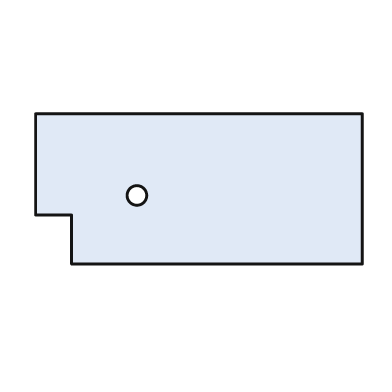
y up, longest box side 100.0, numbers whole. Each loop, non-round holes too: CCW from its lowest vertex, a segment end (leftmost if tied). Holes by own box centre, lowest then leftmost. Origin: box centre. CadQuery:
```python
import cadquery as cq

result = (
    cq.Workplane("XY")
    .moveTo(-39.0, -23.0)
    .lineTo(50.0, -23.0)
    .lineTo(50.0, 23.0)
    .lineTo(-50.0, 23.0)
    .lineTo(-50.0, -8.0)
    .lineTo(-39.0, -8.0)
    .close()
    .moveTo(-19.0, -2.0)
    .circle(3.0)
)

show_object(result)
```